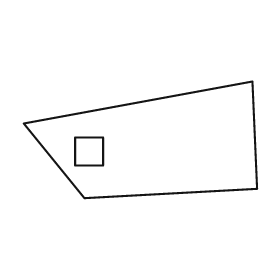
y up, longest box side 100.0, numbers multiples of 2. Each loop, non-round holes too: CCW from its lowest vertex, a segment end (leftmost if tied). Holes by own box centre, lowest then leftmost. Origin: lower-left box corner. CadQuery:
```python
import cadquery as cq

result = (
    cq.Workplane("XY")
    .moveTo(26.0, 0.0)
    .lineTo(100.0, 4.0)
    .lineTo(98.0, 50.0)
    .lineTo(0.0, 32.0)
    .close()
    .moveTo(22.0, 14.0)
    .lineTo(34.0, 14.0)
    .lineTo(34.0, 26.0)
    .lineTo(22.0, 26.0)
    .close()
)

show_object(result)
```